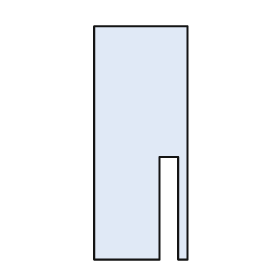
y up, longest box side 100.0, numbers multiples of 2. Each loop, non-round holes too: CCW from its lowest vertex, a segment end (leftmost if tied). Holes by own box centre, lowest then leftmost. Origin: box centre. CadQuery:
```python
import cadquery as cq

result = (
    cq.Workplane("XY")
    .moveTo(-20.0, -50.0)
    .lineTo(8.0, -50.0)
    .lineTo(8.0, -6.0)
    .lineTo(16.0, -6.0)
    .lineTo(16.0, -50.0)
    .lineTo(20.0, -50.0)
    .lineTo(20.0, 50.0)
    .lineTo(-20.0, 50.0)
    .close()
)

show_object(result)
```